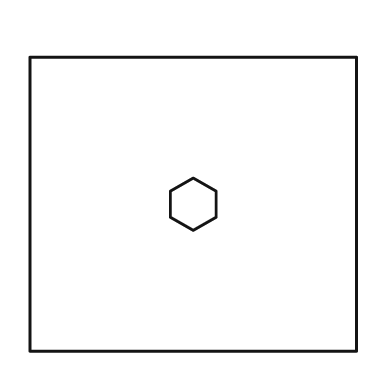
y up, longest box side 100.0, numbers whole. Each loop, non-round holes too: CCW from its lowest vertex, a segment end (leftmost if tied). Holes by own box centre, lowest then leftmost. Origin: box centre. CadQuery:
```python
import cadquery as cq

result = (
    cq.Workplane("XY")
    .moveTo(-50.0, -45.0)
    .lineTo(50.0, -45.0)
    .lineTo(50.0, 45.0)
    .lineTo(-50.0, 45.0)
    .close()
    .moveTo(0.0, -8.0)
    .lineTo(7.0, -4.0)
    .lineTo(7.0, 4.0)
    .lineTo(0.0, 8.0)
    .lineTo(-7.0, 4.0)
    .lineTo(-7.0, -4.0)
    .close()
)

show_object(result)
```